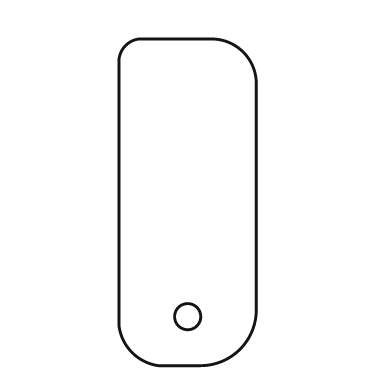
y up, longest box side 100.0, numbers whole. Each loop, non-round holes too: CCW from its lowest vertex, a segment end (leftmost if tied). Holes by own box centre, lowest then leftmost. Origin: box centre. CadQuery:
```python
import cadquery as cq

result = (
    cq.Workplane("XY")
    .moveTo(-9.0, -50.0)
    .lineTo(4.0, -50.0)
    .threePointArc((16.0, -45.0), (21.0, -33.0))
    .lineTo(21.0, 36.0)
    .threePointArc((17.0, 46.0), (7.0, 50.0))
    .lineTo(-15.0, 50.0)
    .threePointArc((-19.0, 48.0), (-21.0, 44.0))
    .lineTo(-21.0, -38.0)
    .threePointArc((-17.0, -46.0), (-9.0, -50.0))
    .close()
    .moveTo(0.0, -35.0)
    .circle(4.0)
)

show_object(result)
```